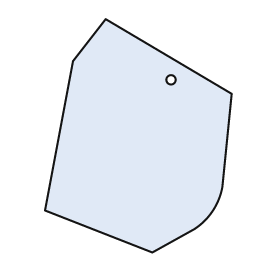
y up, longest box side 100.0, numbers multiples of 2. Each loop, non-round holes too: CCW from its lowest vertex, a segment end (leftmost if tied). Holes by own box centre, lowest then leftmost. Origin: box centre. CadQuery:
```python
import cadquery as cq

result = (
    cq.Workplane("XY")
    .moveTo(6.0, -50.0)
    .lineTo(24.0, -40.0)
    .threePointArc((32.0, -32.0), (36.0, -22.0))
    .lineTo(40.0, 18.0)
    .lineTo(-14.0, 50.0)
    .lineTo(-28.0, 32.0)
    .lineTo(-40.0, -32.0)
    .close()
    .moveTo(14.0, 24.0)
    .circle(2.0)
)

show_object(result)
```